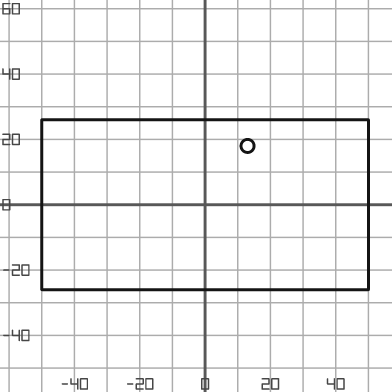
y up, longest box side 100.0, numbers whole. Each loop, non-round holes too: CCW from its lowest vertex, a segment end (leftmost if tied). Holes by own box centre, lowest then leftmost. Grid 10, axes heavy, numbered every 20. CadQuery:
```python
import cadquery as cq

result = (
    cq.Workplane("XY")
    .moveTo(-50.0, -26.0)
    .lineTo(50.0, -26.0)
    .lineTo(50.0, 26.0)
    .lineTo(-50.0, 26.0)
    .close()
    .moveTo(13.0, 18.0)
    .circle(2.0)
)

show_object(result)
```